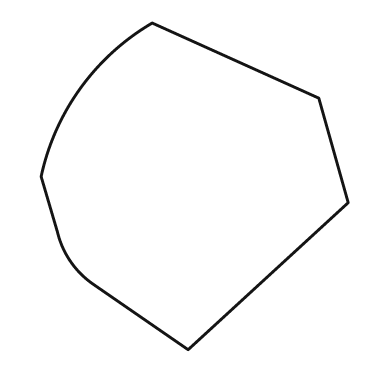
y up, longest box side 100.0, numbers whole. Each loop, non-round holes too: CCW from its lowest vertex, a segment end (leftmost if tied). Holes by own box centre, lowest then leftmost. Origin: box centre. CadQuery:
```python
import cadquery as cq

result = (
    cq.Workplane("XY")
    .moveTo(-2.0, -50.0)
    .lineTo(47.0, -5.0)
    .lineTo(38.0, 27.0)
    .lineTo(-13.0, 50.0)
    .threePointArc((-35.0, 30.0), (-47.0, 3.0))
    .lineTo(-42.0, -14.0)
    .threePointArc((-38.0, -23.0), (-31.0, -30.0))
    .close()
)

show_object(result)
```